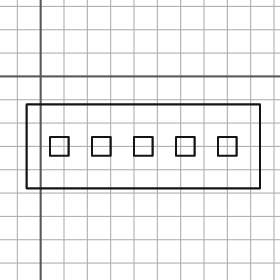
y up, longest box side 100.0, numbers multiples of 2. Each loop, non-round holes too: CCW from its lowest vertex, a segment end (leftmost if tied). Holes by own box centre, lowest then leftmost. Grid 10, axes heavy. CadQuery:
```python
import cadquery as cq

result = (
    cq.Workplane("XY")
    .moveTo(-6.0, -48.0)
    .lineTo(94.0, -48.0)
    .lineTo(94.0, -12.0)
    .lineTo(-6.0, -12.0)
    .close()
    .moveTo(4.0, -34.0)
    .lineTo(12.0, -34.0)
    .lineTo(12.0, -26.0)
    .lineTo(4.0, -26.0)
    .close()
    .moveTo(22.0, -34.0)
    .lineTo(30.0, -34.0)
    .lineTo(30.0, -26.0)
    .lineTo(22.0, -26.0)
    .close()
    .moveTo(40.0, -34.0)
    .lineTo(48.0, -34.0)
    .lineTo(48.0, -26.0)
    .lineTo(40.0, -26.0)
    .close()
    .moveTo(58.0, -34.0)
    .lineTo(66.0, -34.0)
    .lineTo(66.0, -26.0)
    .lineTo(58.0, -26.0)
    .close()
    .moveTo(76.0, -34.0)
    .lineTo(84.0, -34.0)
    .lineTo(84.0, -26.0)
    .lineTo(76.0, -26.0)
    .close()
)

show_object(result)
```